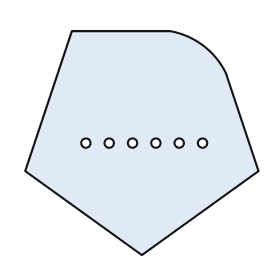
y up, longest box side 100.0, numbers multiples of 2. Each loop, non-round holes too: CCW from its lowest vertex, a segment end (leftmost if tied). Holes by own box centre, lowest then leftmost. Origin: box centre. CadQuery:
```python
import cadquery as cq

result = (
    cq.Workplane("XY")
    .moveTo(0.0, -48.0)
    .lineTo(50.0, -12.0)
    .lineTo(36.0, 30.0)
    .threePointArc((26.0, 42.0), (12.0, 48.0))
    .lineTo(-30.0, 48.0)
    .lineTo(-50.0, -12.0)
    .close()
    .moveTo(-24.0, 0.0)
    .circle(2.0)
    .moveTo(-14.0, 0.0)
    .circle(2.0)
    .moveTo(-4.0, 0.0)
    .circle(2.0)
    .moveTo(6.0, 0.0)
    .circle(2.0)
    .moveTo(16.0, 0.0)
    .circle(2.0)
    .moveTo(26.0, 0.0)
    .circle(2.0)
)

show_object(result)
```